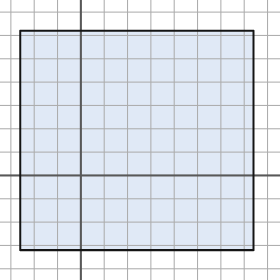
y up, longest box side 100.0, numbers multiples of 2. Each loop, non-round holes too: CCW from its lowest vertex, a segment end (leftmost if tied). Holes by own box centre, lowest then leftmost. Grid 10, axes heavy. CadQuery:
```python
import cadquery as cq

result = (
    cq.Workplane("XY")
    .moveTo(-26.0, -32.0)
    .lineTo(74.0, -32.0)
    .lineTo(74.0, 62.0)
    .lineTo(-26.0, 62.0)
    .close()
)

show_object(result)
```